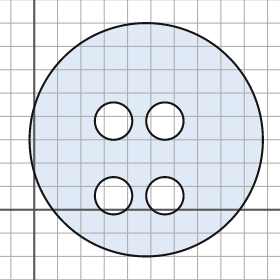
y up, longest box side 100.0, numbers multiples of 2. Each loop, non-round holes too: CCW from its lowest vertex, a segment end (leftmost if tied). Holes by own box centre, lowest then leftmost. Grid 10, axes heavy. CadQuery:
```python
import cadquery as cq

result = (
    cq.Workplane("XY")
    .moveTo(48.0, 30.0)
    .circle(50.0)
    .moveTo(34.0, 6.0)
    .circle(8.0)
    .moveTo(56.0, 6.0)
    .circle(8.0)
    .moveTo(34.0, 38.0)
    .circle(8.0)
    .moveTo(56.0, 38.0)
    .circle(8.0)
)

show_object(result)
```